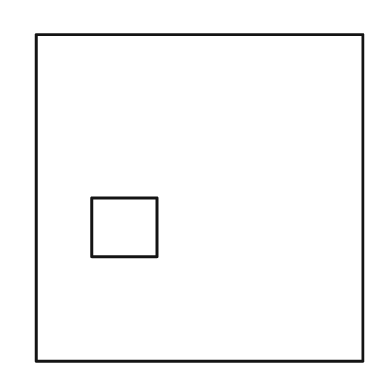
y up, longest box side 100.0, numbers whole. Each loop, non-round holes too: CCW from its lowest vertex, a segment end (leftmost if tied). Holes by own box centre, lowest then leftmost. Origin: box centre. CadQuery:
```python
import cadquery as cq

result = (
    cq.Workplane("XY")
    .moveTo(-50.0, -50.0)
    .lineTo(50.0, -50.0)
    .lineTo(50.0, 50.0)
    .lineTo(-50.0, 50.0)
    .close()
    .moveTo(-33.0, -18.0)
    .lineTo(-13.0, -18.0)
    .lineTo(-13.0, 0.0)
    .lineTo(-33.0, 0.0)
    .close()
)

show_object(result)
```